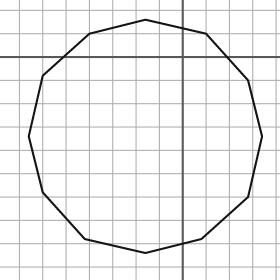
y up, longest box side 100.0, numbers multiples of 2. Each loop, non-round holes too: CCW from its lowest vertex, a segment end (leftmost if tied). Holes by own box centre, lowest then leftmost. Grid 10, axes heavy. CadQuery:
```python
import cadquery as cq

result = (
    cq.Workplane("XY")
    .moveTo(-16.0, -84.0)
    .lineTo(8.0, -78.0)
    .lineTo(28.0, -60.0)
    .lineTo(34.0, -34.0)
    .lineTo(28.0, -10.0)
    .lineTo(10.0, 10.0)
    .lineTo(-16.0, 16.0)
    .lineTo(-40.0, 10.0)
    .lineTo(-60.0, -8.0)
    .lineTo(-66.0, -34.0)
    .lineTo(-60.0, -58.0)
    .lineTo(-42.0, -78.0)
    .close()
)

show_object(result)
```